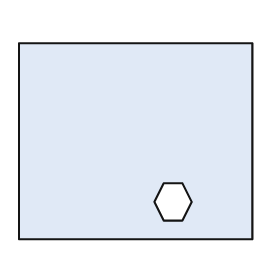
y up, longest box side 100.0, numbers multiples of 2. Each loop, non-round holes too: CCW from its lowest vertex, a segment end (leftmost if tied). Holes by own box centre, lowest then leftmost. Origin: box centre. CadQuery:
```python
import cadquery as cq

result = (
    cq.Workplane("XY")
    .moveTo(-50.0, -42.0)
    .lineTo(50.0, -42.0)
    .lineTo(50.0, 42.0)
    .lineTo(-50.0, 42.0)
    .close()
    .moveTo(12.0, -34.0)
    .lineTo(20.0, -34.0)
    .lineTo(24.0, -26.0)
    .lineTo(20.0, -18.0)
    .lineTo(12.0, -18.0)
    .lineTo(8.0, -26.0)
    .close()
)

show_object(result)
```